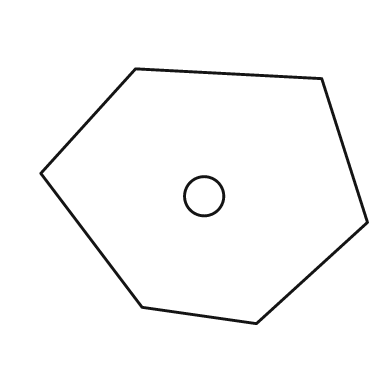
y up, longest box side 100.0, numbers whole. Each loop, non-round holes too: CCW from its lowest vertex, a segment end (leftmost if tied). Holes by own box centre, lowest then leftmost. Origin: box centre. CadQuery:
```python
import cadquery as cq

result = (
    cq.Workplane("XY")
    .moveTo(16.0, -39.0)
    .lineTo(50.0, -8.0)
    .lineTo(36.0, 36.0)
    .lineTo(-21.0, 39.0)
    .lineTo(-50.0, 7.0)
    .lineTo(-19.0, -34.0)
    .close()
    .moveTo(0.0, 0.0)
    .circle(6.0)
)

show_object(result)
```